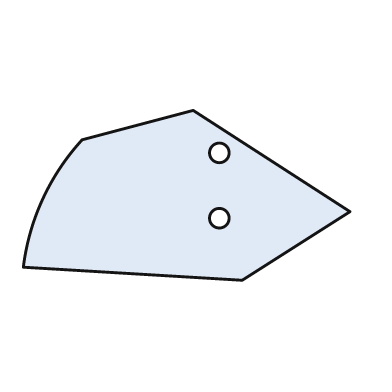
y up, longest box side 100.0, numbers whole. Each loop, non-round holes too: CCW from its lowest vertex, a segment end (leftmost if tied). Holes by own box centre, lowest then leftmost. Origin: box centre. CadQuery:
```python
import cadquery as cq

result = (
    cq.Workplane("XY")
    .moveTo(17.0, -26.0)
    .lineTo(50.0, -5.0)
    .lineTo(2.0, 26.0)
    .lineTo(-32.0, 17.0)
    .threePointArc((-44.0, -1.0), (-50.0, -22.0))
    .close()
    .moveTo(10.0, -7.0)
    .circle(3.0)
    .moveTo(10.0, 13.0)
    .circle(3.0)
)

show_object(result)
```